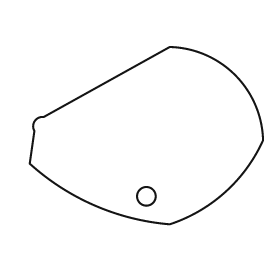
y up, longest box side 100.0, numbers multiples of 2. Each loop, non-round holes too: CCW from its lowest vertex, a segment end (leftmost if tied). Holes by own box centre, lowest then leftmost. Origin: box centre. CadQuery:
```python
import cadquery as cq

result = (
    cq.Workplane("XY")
    .moveTo(10.0, -38.0)
    .threePointArc((34.0, -24.0), (50.0, -2.0))
    .threePointArc((38.0, 26.0), (10.0, 38.0))
    .lineTo(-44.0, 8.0)
    .threePointArc((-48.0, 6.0), (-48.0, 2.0))
    .lineTo(-50.0, -12.0)
    .threePointArc((-22.0, -30.0), (10.0, -38.0))
    .close()
    .moveTo(0.0, -26.0)
    .circle(4.0)
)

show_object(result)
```